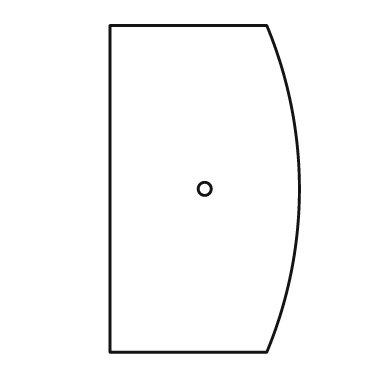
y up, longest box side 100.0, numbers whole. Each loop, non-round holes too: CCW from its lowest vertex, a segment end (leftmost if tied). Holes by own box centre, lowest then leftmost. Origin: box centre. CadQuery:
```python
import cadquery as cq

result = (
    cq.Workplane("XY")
    .moveTo(-29.0, -50.0)
    .lineTo(19.0, -50.0)
    .threePointArc((29.0, 0.0), (19.0, 50.0))
    .lineTo(-29.0, 50.0)
    .close()
    .moveTo(0.0, 0.0)
    .circle(2.0)
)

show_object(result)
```